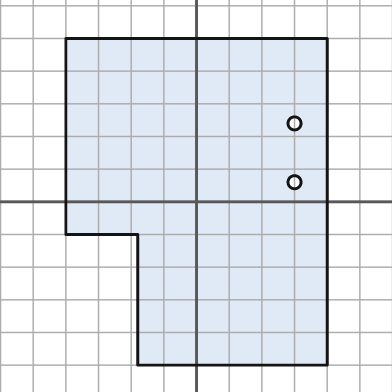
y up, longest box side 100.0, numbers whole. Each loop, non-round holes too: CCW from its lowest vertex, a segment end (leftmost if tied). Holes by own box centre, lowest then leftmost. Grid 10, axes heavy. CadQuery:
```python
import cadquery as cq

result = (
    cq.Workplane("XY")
    .moveTo(-18.0, -50.0)
    .lineTo(40.0, -50.0)
    .lineTo(40.0, 50.0)
    .lineTo(-40.0, 50.0)
    .lineTo(-40.0, -10.0)
    .lineTo(-18.0, -10.0)
    .close()
    .moveTo(30.0, 6.0)
    .circle(2.0)
    .moveTo(30.0, 24.0)
    .circle(2.0)
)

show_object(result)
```